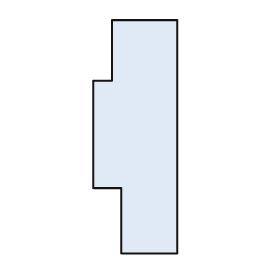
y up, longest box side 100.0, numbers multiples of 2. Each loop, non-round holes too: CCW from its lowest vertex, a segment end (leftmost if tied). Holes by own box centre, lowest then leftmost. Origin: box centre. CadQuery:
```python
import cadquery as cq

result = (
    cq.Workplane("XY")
    .moveTo(-6.0, -50.0)
    .lineTo(18.0, -50.0)
    .lineTo(18.0, 50.0)
    .lineTo(-10.0, 50.0)
    .lineTo(-10.0, 24.0)
    .lineTo(-18.0, 24.0)
    .lineTo(-18.0, -22.0)
    .lineTo(-6.0, -22.0)
    .close()
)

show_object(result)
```